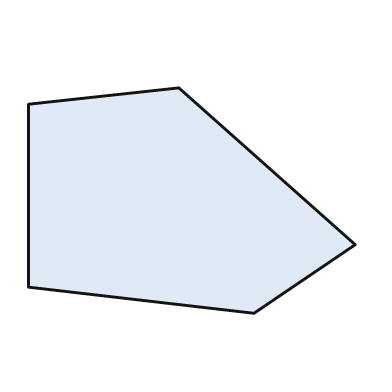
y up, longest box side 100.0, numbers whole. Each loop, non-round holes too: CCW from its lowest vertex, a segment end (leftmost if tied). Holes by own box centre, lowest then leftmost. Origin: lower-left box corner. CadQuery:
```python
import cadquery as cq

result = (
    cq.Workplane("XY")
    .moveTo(69.0, 0.0)
    .lineTo(100.0, 21.0)
    .lineTo(46.0, 69.0)
    .lineTo(0.0, 64.0)
    .lineTo(0.0, 8.0)
    .close()
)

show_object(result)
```